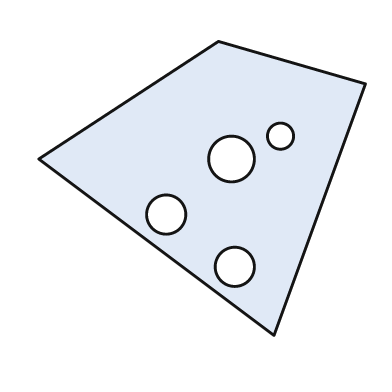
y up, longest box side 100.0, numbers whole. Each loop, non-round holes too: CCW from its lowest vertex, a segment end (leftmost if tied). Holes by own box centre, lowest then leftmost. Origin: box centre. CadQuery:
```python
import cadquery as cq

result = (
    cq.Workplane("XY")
    .moveTo(22.0, -45.0)
    .lineTo(50.0, 32.0)
    .lineTo(5.0, 45.0)
    .lineTo(-50.0, 9.0)
    .close()
    .moveTo(10.0, -24.0)
    .circle(6.0)
    .moveTo(-11.0, -8.0)
    .circle(6.0)
    .moveTo(9.0, 9.0)
    .circle(7.0)
    .moveTo(24.0, 16.0)
    .circle(4.0)
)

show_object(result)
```